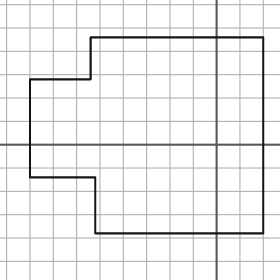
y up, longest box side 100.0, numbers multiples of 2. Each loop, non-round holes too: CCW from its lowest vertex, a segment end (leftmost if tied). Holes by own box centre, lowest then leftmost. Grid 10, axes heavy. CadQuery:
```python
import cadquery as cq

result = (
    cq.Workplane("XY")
    .moveTo(-52.0, -38.0)
    .lineTo(20.0, -38.0)
    .lineTo(20.0, 46.0)
    .lineTo(-54.0, 46.0)
    .lineTo(-54.0, 28.0)
    .lineTo(-80.0, 28.0)
    .lineTo(-80.0, -14.0)
    .lineTo(-52.0, -14.0)
    .close()
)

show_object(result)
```